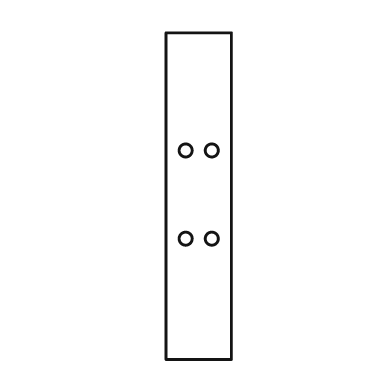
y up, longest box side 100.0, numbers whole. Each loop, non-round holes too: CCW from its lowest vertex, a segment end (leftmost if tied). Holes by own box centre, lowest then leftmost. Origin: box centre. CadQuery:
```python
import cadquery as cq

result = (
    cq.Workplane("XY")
    .moveTo(-10.0, -50.0)
    .lineTo(10.0, -50.0)
    .lineTo(10.0, 50.0)
    .lineTo(-10.0, 50.0)
    .close()
    .moveTo(-4.0, -13.0)
    .circle(2.0)
    .moveTo(4.0, -13.0)
    .circle(2.0)
    .moveTo(-4.0, 14.0)
    .circle(2.0)
    .moveTo(4.0, 14.0)
    .circle(2.0)
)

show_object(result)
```